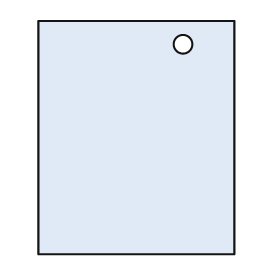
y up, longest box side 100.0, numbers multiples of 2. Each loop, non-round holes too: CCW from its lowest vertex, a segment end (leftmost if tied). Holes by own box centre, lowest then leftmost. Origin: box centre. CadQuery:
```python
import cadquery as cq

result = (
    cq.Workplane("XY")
    .moveTo(-42.0, -50.0)
    .lineTo(42.0, -50.0)
    .lineTo(42.0, 50.0)
    .lineTo(-42.0, 50.0)
    .close()
    .moveTo(20.0, 40.0)
    .circle(4.0)
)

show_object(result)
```